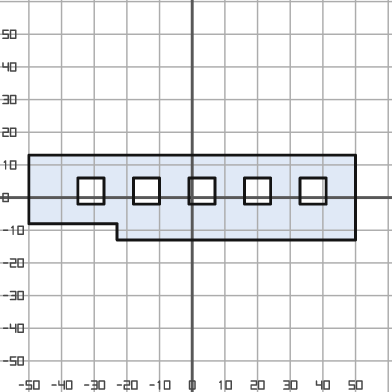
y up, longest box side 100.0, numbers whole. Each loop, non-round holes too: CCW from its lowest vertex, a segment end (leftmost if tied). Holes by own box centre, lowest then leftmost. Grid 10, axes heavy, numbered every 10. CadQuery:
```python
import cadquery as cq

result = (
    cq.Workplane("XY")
    .moveTo(-23.0, -13.0)
    .lineTo(50.0, -13.0)
    .lineTo(50.0, 13.0)
    .lineTo(-50.0, 13.0)
    .lineTo(-50.0, -8.0)
    .lineTo(-23.0, -8.0)
    .close()
    .moveTo(-35.0, -2.0)
    .lineTo(-27.0, -2.0)
    .lineTo(-27.0, 6.0)
    .lineTo(-35.0, 6.0)
    .close()
    .moveTo(-18.0, -2.0)
    .lineTo(-10.0, -2.0)
    .lineTo(-10.0, 6.0)
    .lineTo(-18.0, 6.0)
    .close()
    .moveTo(-1.0, -2.0)
    .lineTo(7.0, -2.0)
    .lineTo(7.0, 6.0)
    .lineTo(-1.0, 6.0)
    .close()
    .moveTo(16.0, -2.0)
    .lineTo(24.0, -2.0)
    .lineTo(24.0, 6.0)
    .lineTo(16.0, 6.0)
    .close()
    .moveTo(33.0, -2.0)
    .lineTo(41.0, -2.0)
    .lineTo(41.0, 6.0)
    .lineTo(33.0, 6.0)
    .close()
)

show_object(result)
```